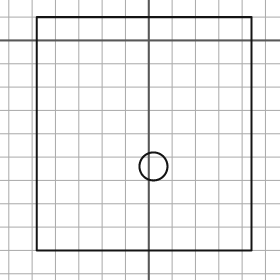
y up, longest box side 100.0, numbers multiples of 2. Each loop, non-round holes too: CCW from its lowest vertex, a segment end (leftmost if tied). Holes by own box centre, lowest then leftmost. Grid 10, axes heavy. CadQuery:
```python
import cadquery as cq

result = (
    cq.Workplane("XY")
    .moveTo(-48.0, -90.0)
    .lineTo(44.0, -90.0)
    .lineTo(44.0, 10.0)
    .lineTo(-48.0, 10.0)
    .close()
    .moveTo(2.0, -54.0)
    .circle(6.0)
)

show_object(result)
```